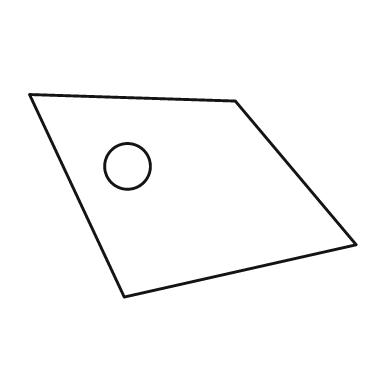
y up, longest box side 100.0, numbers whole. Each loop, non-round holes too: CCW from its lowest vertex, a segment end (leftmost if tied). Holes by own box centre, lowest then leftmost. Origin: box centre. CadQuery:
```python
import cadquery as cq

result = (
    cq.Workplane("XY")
    .moveTo(-21.0, -31.0)
    .lineTo(50.0, -15.0)
    .lineTo(13.0, 29.0)
    .lineTo(-50.0, 31.0)
    .close()
    .moveTo(-20.0, 9.0)
    .circle(7.0)
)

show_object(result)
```